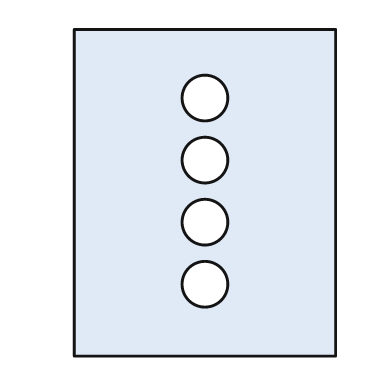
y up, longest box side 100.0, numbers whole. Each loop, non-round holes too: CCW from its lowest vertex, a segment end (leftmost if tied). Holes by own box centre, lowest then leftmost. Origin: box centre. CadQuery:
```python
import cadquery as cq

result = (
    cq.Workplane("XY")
    .moveTo(-40.0, -50.0)
    .lineTo(40.0, -50.0)
    .lineTo(40.0, 50.0)
    .lineTo(-40.0, 50.0)
    .close()
    .moveTo(0.0, -28.0)
    .circle(7.0)
    .moveTo(0.0, -9.0)
    .circle(7.0)
    .moveTo(0.0, 10.0)
    .circle(7.0)
    .moveTo(0.0, 29.0)
    .circle(7.0)
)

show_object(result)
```